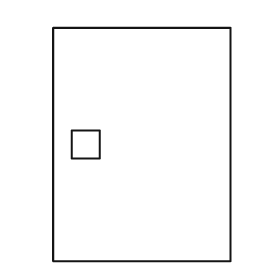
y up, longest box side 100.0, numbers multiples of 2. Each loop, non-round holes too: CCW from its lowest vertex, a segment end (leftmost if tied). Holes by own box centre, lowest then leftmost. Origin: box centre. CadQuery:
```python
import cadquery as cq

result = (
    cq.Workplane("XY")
    .moveTo(-38.0, -50.0)
    .lineTo(38.0, -50.0)
    .lineTo(38.0, 50.0)
    .lineTo(-38.0, 50.0)
    .close()
    .moveTo(-30.0, -6.0)
    .lineTo(-18.0, -6.0)
    .lineTo(-18.0, 6.0)
    .lineTo(-30.0, 6.0)
    .close()
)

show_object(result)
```